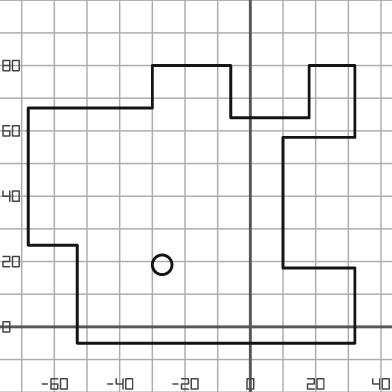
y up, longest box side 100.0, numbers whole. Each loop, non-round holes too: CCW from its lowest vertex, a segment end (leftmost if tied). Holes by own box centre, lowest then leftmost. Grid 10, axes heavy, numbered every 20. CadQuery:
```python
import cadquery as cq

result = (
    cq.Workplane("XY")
    .moveTo(-53.0, -5.0)
    .lineTo(32.0, -5.0)
    .lineTo(32.0, 18.0)
    .lineTo(10.0, 18.0)
    .lineTo(10.0, 58.0)
    .lineTo(32.0, 58.0)
    .lineTo(32.0, 80.0)
    .lineTo(18.0, 80.0)
    .lineTo(18.0, 64.0)
    .lineTo(-6.0, 64.0)
    .lineTo(-6.0, 80.0)
    .lineTo(-30.0, 80.0)
    .lineTo(-30.0, 67.0)
    .lineTo(-68.0, 67.0)
    .lineTo(-68.0, 25.0)
    .lineTo(-53.0, 25.0)
    .close()
    .moveTo(-27.0, 19.0)
    .circle(3.0)
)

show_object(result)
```